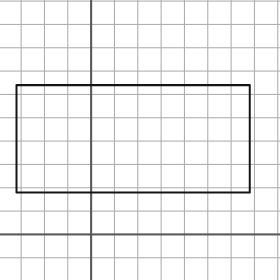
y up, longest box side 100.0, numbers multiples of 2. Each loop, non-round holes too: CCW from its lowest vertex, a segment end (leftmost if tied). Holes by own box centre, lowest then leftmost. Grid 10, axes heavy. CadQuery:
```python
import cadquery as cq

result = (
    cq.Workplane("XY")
    .moveTo(-32.0, 18.0)
    .lineTo(68.0, 18.0)
    .lineTo(68.0, 64.0)
    .lineTo(-32.0, 64.0)
    .close()
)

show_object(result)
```